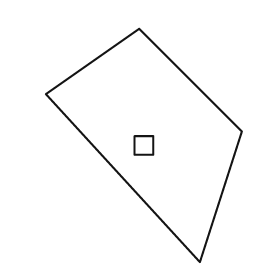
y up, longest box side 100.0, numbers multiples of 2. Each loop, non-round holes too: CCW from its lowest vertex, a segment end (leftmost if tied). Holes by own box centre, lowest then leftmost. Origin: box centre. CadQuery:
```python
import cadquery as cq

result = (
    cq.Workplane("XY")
    .moveTo(24.0, -50.0)
    .lineTo(42.0, 6.0)
    .lineTo(-2.0, 50.0)
    .lineTo(-42.0, 22.0)
    .close()
    .moveTo(-4.0, -4.0)
    .lineTo(4.0, -4.0)
    .lineTo(4.0, 4.0)
    .lineTo(-4.0, 4.0)
    .close()
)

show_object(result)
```